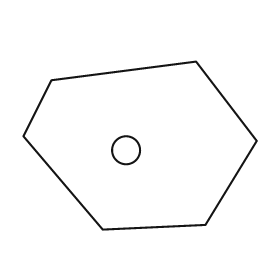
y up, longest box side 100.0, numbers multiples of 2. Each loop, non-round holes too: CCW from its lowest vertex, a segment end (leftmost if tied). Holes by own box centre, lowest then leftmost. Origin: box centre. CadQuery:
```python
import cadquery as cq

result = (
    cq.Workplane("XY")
    .moveTo(-16.0, -36.0)
    .lineTo(28.0, -34.0)
    .lineTo(50.0, 2.0)
    .lineTo(24.0, 36.0)
    .lineTo(-38.0, 28.0)
    .lineTo(-50.0, 4.0)
    .close()
    .moveTo(-6.0, -2.0)
    .circle(6.0)
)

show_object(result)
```